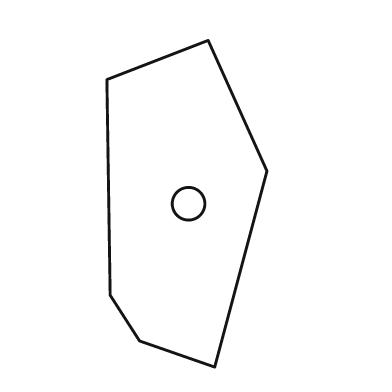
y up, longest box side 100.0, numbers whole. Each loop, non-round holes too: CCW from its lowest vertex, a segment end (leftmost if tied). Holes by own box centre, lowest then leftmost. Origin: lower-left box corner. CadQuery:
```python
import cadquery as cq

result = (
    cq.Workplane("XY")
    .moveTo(33.0, 0.0)
    .lineTo(49.0, 60.0)
    .lineTo(31.0, 100.0)
    .lineTo(0.0, 88.0)
    .lineTo(1.0, 22.0)
    .lineTo(10.0, 8.0)
    .close()
    .moveTo(25.0, 50.0)
    .circle(5.0)
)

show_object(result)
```